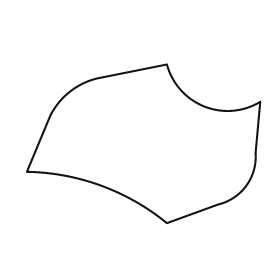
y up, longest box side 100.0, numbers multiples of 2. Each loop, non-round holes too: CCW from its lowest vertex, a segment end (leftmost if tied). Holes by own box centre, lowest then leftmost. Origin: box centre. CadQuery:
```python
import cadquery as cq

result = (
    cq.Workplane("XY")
    .moveTo(10.0, -34.0)
    .lineTo(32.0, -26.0)
    .threePointArc((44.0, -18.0), (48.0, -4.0))
    .lineTo(50.0, 18.0)
    .threePointArc((26.0, 16.0), (10.0, 34.0))
    .lineTo(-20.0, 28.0)
    .threePointArc((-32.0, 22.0), (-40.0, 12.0))
    .lineTo(-50.0, -12.0)
    .threePointArc((-18.0, -18.0), (10.0, -34.0))
    .close()
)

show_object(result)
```